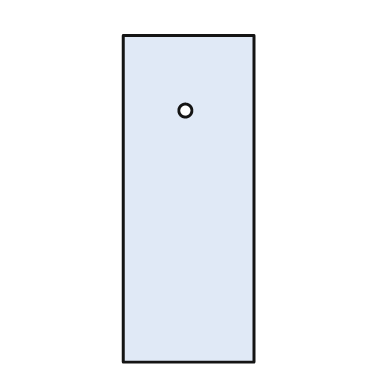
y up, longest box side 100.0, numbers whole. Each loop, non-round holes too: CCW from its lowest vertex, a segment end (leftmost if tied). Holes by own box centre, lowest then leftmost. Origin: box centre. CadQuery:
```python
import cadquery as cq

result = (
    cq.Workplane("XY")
    .moveTo(-20.0, -50.0)
    .lineTo(20.0, -50.0)
    .lineTo(20.0, 50.0)
    .lineTo(-20.0, 50.0)
    .close()
    .moveTo(-1.0, 27.0)
    .circle(2.0)
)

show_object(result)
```